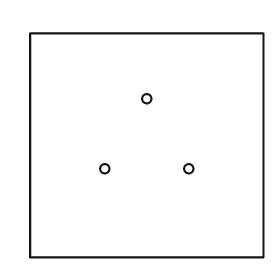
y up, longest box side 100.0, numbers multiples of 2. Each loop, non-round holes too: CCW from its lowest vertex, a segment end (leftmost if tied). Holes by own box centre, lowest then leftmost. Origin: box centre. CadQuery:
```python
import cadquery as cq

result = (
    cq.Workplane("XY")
    .moveTo(-50.0, -48.0)
    .lineTo(50.0, -48.0)
    .lineTo(50.0, 48.0)
    .lineTo(-50.0, 48.0)
    .close()
    .moveTo(-18.0, -10.0)
    .circle(2.0)
    .moveTo(18.0, -10.0)
    .circle(2.0)
    .moveTo(0.0, 20.0)
    .circle(2.0)
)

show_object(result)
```